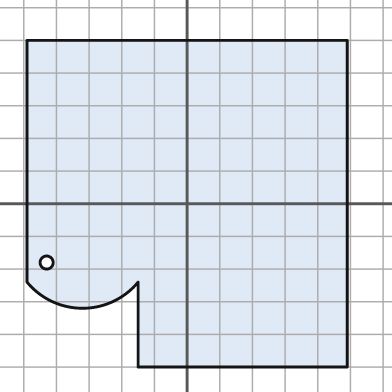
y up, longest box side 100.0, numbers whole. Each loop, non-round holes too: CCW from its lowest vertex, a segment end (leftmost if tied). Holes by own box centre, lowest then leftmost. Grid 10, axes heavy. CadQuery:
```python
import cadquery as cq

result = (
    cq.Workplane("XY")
    .moveTo(-15.0, -50.0)
    .lineTo(49.0, -50.0)
    .lineTo(49.0, 50.0)
    .lineTo(-49.0, 50.0)
    .lineTo(-49.0, -24.0)
    .threePointArc((-32.0, -32.0), (-15.0, -24.0))
    .close()
    .moveTo(-43.0, -18.0)
    .circle(2.0)
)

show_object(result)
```